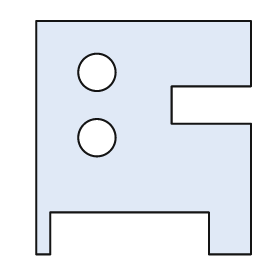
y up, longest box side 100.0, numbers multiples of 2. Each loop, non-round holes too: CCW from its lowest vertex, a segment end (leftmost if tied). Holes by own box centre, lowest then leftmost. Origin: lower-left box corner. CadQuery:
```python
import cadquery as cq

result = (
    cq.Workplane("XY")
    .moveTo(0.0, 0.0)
    .lineTo(6.0, 0.0)
    .lineTo(6.0, 18.0)
    .lineTo(74.0, 18.0)
    .lineTo(74.0, 0.0)
    .lineTo(92.0, 0.0)
    .lineTo(92.0, 56.0)
    .lineTo(58.0, 56.0)
    .lineTo(58.0, 72.0)
    .lineTo(92.0, 72.0)
    .lineTo(92.0, 100.0)
    .lineTo(0.0, 100.0)
    .close()
    .moveTo(26.0, 50.0)
    .circle(8.0)
    .moveTo(26.0, 78.0)
    .circle(8.0)
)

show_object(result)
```